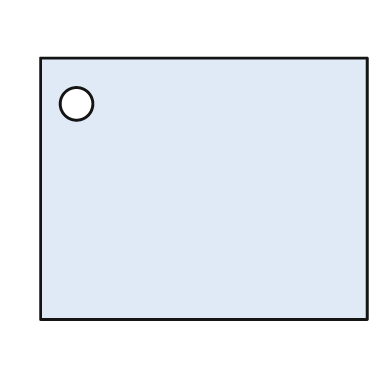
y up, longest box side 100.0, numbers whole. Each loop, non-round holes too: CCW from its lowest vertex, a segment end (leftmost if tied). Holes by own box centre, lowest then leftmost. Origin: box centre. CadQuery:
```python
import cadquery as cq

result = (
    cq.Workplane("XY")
    .moveTo(-50.0, -40.0)
    .lineTo(50.0, -40.0)
    .lineTo(50.0, 40.0)
    .lineTo(-50.0, 40.0)
    .close()
    .moveTo(-39.0, 26.0)
    .circle(5.0)
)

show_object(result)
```